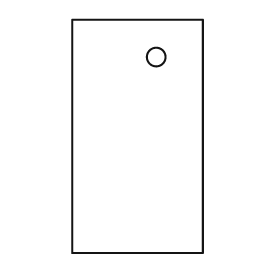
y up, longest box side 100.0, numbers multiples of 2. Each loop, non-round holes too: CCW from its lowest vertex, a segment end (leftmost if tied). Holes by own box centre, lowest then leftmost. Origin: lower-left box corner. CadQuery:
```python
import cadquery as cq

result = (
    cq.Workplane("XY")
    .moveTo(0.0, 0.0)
    .lineTo(56.0, 0.0)
    .lineTo(56.0, 100.0)
    .lineTo(0.0, 100.0)
    .close()
    .moveTo(36.0, 84.0)
    .circle(4.0)
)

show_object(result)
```